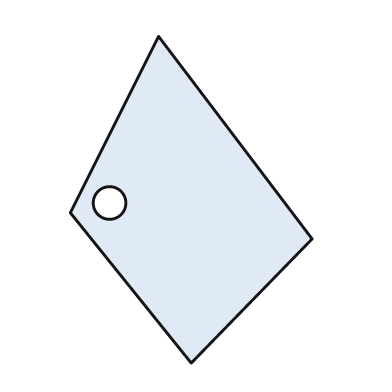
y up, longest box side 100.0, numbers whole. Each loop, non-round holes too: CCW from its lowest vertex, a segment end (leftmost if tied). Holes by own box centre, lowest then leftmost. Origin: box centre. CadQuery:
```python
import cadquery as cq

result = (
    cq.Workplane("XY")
    .moveTo(0.0, -50.0)
    .lineTo(37.0, -12.0)
    .lineTo(-10.0, 50.0)
    .lineTo(-37.0, -4.0)
    .close()
    .moveTo(-25.0, -1.0)
    .circle(5.0)
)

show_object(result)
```